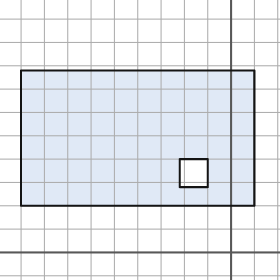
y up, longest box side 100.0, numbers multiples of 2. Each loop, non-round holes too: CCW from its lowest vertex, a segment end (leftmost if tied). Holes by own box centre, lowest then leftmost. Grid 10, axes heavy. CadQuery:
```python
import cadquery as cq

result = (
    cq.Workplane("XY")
    .moveTo(-90.0, 20.0)
    .lineTo(10.0, 20.0)
    .lineTo(10.0, 78.0)
    .lineTo(-90.0, 78.0)
    .close()
    .moveTo(-22.0, 28.0)
    .lineTo(-10.0, 28.0)
    .lineTo(-10.0, 40.0)
    .lineTo(-22.0, 40.0)
    .close()
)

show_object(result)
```